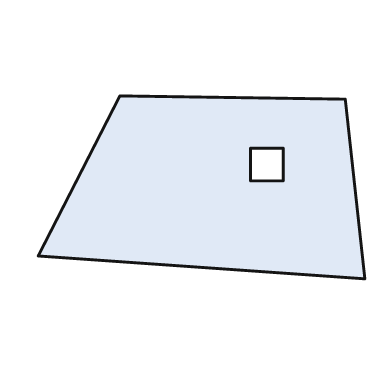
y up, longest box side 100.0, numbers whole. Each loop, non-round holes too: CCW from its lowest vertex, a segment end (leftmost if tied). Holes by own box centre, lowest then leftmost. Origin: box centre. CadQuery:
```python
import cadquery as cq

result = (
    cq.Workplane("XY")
    .moveTo(50.0, -28.0)
    .lineTo(44.0, 27.0)
    .lineTo(-25.0, 28.0)
    .lineTo(-50.0, -21.0)
    .close()
    .moveTo(15.0, 2.0)
    .lineTo(25.0, 2.0)
    .lineTo(25.0, 12.0)
    .lineTo(15.0, 12.0)
    .close()
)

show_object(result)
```